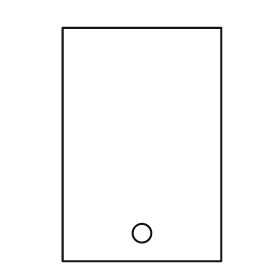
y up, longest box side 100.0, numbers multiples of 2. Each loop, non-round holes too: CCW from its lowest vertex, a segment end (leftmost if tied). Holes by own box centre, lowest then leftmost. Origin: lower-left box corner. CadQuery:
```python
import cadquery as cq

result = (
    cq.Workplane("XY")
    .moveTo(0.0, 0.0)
    .lineTo(68.0, 0.0)
    .lineTo(68.0, 100.0)
    .lineTo(0.0, 100.0)
    .close()
    .moveTo(34.0, 12.0)
    .circle(4.0)
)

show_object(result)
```